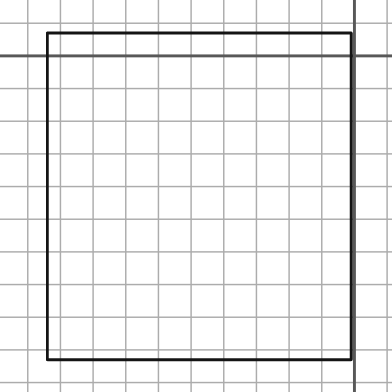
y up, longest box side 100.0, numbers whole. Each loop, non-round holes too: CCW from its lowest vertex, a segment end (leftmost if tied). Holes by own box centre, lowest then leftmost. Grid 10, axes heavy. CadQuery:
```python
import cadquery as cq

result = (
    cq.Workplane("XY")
    .moveTo(-94.0, -93.0)
    .lineTo(-1.0, -93.0)
    .lineTo(-1.0, 7.0)
    .lineTo(-94.0, 7.0)
    .close()
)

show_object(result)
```